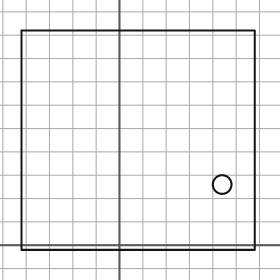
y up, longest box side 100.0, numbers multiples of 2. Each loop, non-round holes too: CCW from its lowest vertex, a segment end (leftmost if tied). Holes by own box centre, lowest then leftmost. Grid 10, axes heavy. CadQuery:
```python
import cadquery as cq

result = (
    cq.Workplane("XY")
    .moveTo(-42.0, -2.0)
    .lineTo(58.0, -2.0)
    .lineTo(58.0, 92.0)
    .lineTo(-42.0, 92.0)
    .close()
    .moveTo(44.0, 26.0)
    .circle(4.0)
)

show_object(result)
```